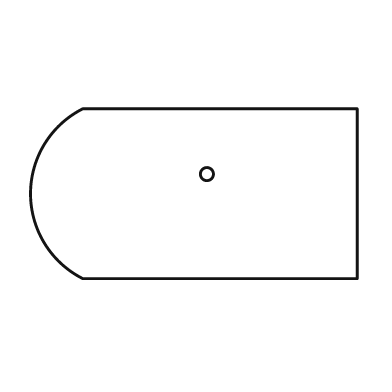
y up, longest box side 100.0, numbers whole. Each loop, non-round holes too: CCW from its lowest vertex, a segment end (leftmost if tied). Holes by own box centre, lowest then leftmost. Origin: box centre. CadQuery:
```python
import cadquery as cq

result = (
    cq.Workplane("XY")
    .moveTo(-34.0, -26.0)
    .lineTo(50.0, -26.0)
    .lineTo(50.0, 26.0)
    .lineTo(-34.0, 26.0)
    .threePointArc((-50.0, 0.0), (-34.0, -26.0))
    .close()
    .moveTo(4.0, 6.0)
    .circle(2.0)
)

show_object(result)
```